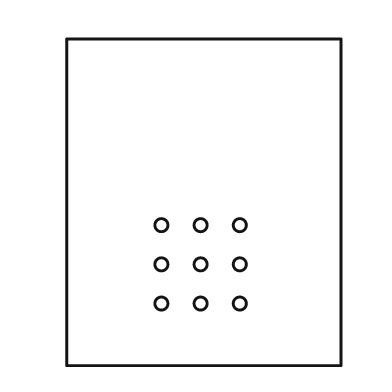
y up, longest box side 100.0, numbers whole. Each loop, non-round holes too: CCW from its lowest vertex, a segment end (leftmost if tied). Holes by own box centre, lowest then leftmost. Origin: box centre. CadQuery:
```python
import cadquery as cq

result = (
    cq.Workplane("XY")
    .moveTo(-42.0, -50.0)
    .lineTo(42.0, -50.0)
    .lineTo(42.0, 50.0)
    .lineTo(-42.0, 50.0)
    .close()
    .moveTo(-13.0, -31.0)
    .circle(2.0)
    .moveTo(-1.0, -31.0)
    .circle(2.0)
    .moveTo(11.0, -31.0)
    .circle(2.0)
    .moveTo(-13.0, -19.0)
    .circle(2.0)
    .moveTo(-1.0, -19.0)
    .circle(2.0)
    .moveTo(11.0, -19.0)
    .circle(2.0)
    .moveTo(-13.0, -7.0)
    .circle(2.0)
    .moveTo(-1.0, -7.0)
    .circle(2.0)
    .moveTo(11.0, -7.0)
    .circle(2.0)
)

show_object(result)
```